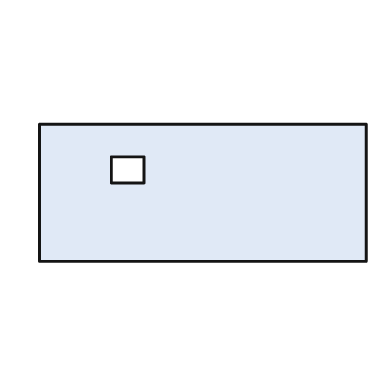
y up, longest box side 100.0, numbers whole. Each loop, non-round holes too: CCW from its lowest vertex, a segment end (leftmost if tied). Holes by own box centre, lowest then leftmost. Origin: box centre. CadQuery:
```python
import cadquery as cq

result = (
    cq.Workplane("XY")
    .moveTo(-50.0, -21.0)
    .lineTo(50.0, -21.0)
    .lineTo(50.0, 21.0)
    .lineTo(-50.0, 21.0)
    .close()
    .moveTo(-28.0, 3.0)
    .lineTo(-18.0, 3.0)
    .lineTo(-18.0, 11.0)
    .lineTo(-28.0, 11.0)
    .close()
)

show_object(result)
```